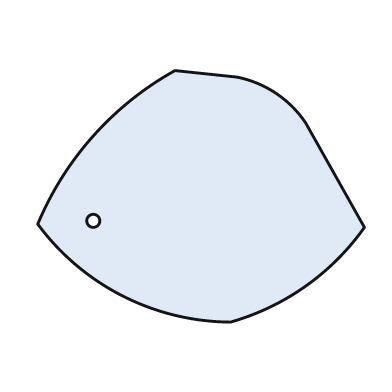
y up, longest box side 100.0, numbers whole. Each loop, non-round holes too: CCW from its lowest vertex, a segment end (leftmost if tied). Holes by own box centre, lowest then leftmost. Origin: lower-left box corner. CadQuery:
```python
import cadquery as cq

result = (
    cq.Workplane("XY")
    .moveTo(59.0, 0.0)
    .threePointArc((82.0, 11.0), (100.0, 29.0))
    .lineTo(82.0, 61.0)
    .threePointArc((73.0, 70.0), (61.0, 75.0))
    .lineTo(42.0, 77.0)
    .threePointArc((17.0, 57.0), (0.0, 30.0))
    .threePointArc((26.0, 8.0), (59.0, 0.0))
    .close()
    .moveTo(17.0, 31.0)
    .circle(2.0)
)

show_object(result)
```